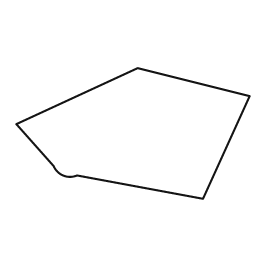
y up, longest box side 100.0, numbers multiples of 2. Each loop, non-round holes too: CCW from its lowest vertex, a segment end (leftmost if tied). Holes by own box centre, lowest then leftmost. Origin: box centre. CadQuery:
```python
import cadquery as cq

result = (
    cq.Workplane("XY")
    .moveTo(30.0, -28.0)
    .lineTo(50.0, 16.0)
    .lineTo(2.0, 28.0)
    .lineTo(-50.0, 4.0)
    .lineTo(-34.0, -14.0)
    .threePointArc((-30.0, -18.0), (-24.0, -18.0))
    .close()
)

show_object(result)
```